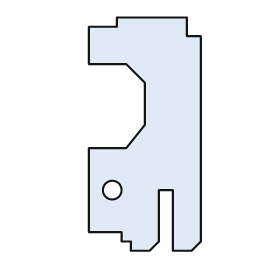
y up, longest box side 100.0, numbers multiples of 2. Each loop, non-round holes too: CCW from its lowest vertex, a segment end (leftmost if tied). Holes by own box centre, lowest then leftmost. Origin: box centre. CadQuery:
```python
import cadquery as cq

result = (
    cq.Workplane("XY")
    .moveTo(-6.0, -50.0)
    .lineTo(2.0, -50.0)
    .lineTo(6.0, -46.0)
    .lineTo(6.0, -24.0)
    .lineTo(12.0, -24.0)
    .lineTo(12.0, -50.0)
    .lineTo(20.0, -50.0)
    .lineTo(24.0, -46.0)
    .lineTo(24.0, 42.0)
    .lineTo(18.0, 42.0)
    .lineTo(18.0, 50.0)
    .lineTo(-12.0, 50.0)
    .lineTo(-12.0, 46.0)
    .lineTo(-24.0, 46.0)
    .lineTo(-24.0, 30.0)
    .lineTo(-8.0, 30.0)
    .lineTo(0.0, 22.0)
    .lineTo(0.0, 4.0)
    .lineTo(-8.0, -6.0)
    .lineTo(-24.0, -6.0)
    .lineTo(-24.0, -42.0)
    .lineTo(-10.0, -42.0)
    .lineTo(-10.0, -46.0)
    .lineTo(-6.0, -46.0)
    .close()
    .moveTo(-14.0, -24.0)
    .circle(4.0)
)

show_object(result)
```